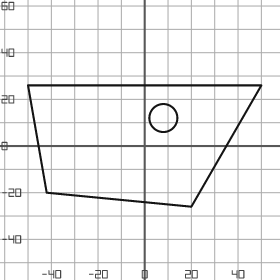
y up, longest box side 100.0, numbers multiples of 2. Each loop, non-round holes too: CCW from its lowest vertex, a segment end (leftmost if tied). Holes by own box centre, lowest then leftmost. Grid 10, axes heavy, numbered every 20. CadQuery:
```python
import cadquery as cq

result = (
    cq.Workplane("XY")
    .moveTo(20.0, -26.0)
    .lineTo(50.0, 26.0)
    .lineTo(-50.0, 26.0)
    .lineTo(-42.0, -20.0)
    .close()
    .moveTo(8.0, 12.0)
    .circle(6.0)
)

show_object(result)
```